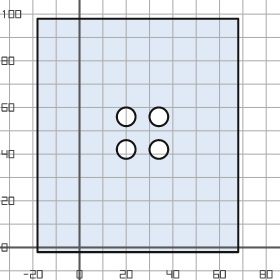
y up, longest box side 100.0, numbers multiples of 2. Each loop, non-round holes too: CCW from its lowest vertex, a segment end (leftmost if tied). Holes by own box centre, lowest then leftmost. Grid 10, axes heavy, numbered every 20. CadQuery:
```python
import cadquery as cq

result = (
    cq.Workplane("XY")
    .moveTo(-18.0, -2.0)
    .lineTo(68.0, -2.0)
    .lineTo(68.0, 98.0)
    .lineTo(-18.0, 98.0)
    .close()
    .moveTo(20.0, 42.0)
    .circle(4.0)
    .moveTo(34.0, 42.0)
    .circle(4.0)
    .moveTo(20.0, 56.0)
    .circle(4.0)
    .moveTo(34.0, 56.0)
    .circle(4.0)
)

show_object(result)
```